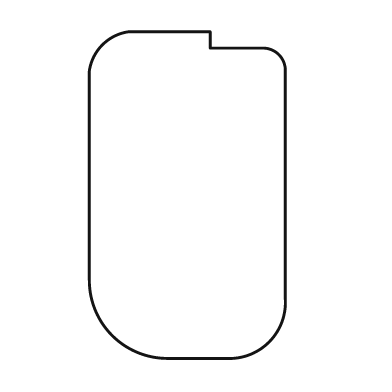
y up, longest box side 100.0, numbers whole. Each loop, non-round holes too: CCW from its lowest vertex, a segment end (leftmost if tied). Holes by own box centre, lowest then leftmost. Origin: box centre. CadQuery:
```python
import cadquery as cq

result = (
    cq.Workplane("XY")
    .moveTo(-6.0, -50.0)
    .lineTo(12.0, -50.0)
    .threePointArc((25.0, -45.0), (30.0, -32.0))
    .lineTo(30.0, 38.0)
    .threePointArc((28.0, 43.0), (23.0, 45.0))
    .lineTo(7.0, 45.0)
    .lineTo(7.0, 50.0)
    .lineTo(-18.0, 50.0)
    .threePointArc((-26.0, 46.0), (-30.0, 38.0))
    .lineTo(-30.0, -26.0)
    .threePointArc((-23.0, -43.0), (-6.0, -50.0))
    .close()
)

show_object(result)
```